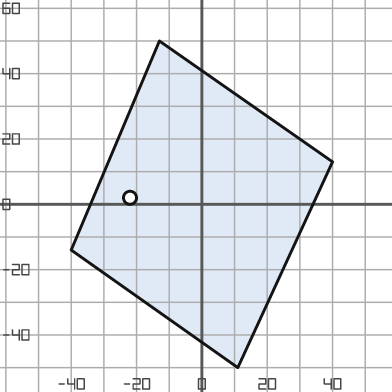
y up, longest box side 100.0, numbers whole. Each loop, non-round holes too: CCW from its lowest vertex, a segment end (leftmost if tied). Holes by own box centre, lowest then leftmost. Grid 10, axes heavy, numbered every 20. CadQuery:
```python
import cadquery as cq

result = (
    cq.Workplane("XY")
    .moveTo(11.0, -50.0)
    .lineTo(40.0, 13.0)
    .lineTo(-13.0, 50.0)
    .lineTo(-40.0, -14.0)
    .close()
    .moveTo(-22.0, 2.0)
    .circle(2.0)
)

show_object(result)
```